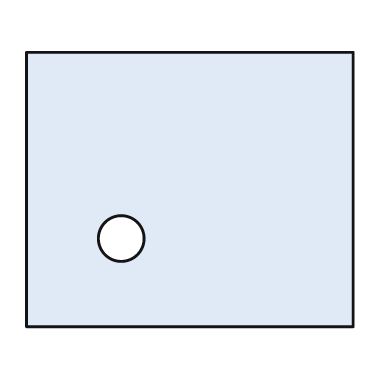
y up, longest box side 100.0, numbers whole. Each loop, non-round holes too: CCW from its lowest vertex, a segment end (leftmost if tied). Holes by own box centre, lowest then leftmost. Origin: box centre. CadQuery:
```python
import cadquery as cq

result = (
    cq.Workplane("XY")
    .moveTo(-50.0, -42.0)
    .lineTo(50.0, -42.0)
    .lineTo(50.0, 42.0)
    .lineTo(-50.0, 42.0)
    .close()
    .moveTo(-21.0, -15.0)
    .circle(7.0)
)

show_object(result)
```